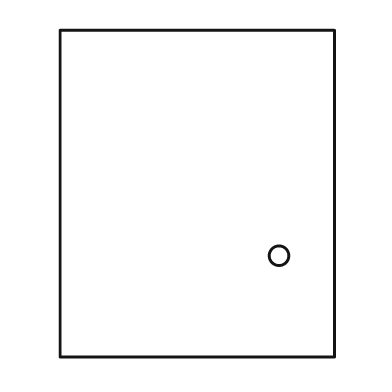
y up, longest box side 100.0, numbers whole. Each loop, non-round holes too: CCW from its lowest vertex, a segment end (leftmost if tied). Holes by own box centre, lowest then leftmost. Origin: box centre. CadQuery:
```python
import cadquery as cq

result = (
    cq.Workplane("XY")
    .moveTo(-42.0, -50.0)
    .lineTo(42.0, -50.0)
    .lineTo(42.0, 50.0)
    .lineTo(-42.0, 50.0)
    .close()
    .moveTo(25.0, -19.0)
    .circle(3.0)
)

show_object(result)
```